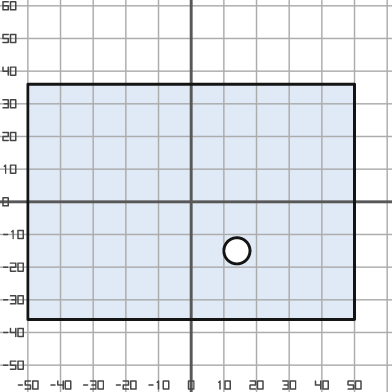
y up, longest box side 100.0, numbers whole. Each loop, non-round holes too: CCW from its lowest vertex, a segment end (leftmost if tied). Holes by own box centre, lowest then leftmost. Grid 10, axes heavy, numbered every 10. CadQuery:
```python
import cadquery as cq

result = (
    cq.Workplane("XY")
    .moveTo(-50.0, -36.0)
    .lineTo(50.0, -36.0)
    .lineTo(50.0, 36.0)
    .lineTo(-50.0, 36.0)
    .close()
    .moveTo(14.0, -15.0)
    .circle(4.0)
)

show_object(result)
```